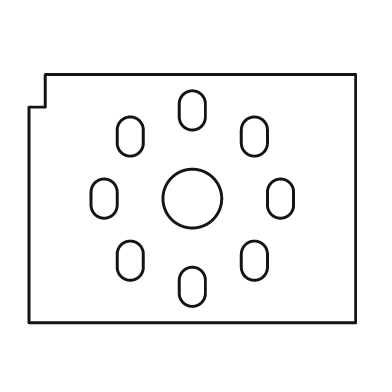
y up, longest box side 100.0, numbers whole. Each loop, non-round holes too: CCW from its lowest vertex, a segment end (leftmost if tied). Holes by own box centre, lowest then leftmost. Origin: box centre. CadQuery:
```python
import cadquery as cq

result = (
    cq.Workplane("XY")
    .moveTo(-50.0, -38.0)
    .lineTo(50.0, -38.0)
    .lineTo(50.0, 38.0)
    .lineTo(-45.0, 38.0)
    .lineTo(-45.0, 28.0)
    .lineTo(-50.0, 28.0)
    .close()
    .moveTo(-4.0, -29.0)
    .threePointArc((0.0, -33.0), (4.0, -29.0))
    .lineTo(4.0, -25.0)
    .threePointArc((0.0, -21.0), (-4.0, -25.0))
    .close()
    .moveTo(-23.0, -21.0)
    .threePointArc((-19.0, -25.0), (-15.0, -21.0))
    .lineTo(-15.0, -17.0)
    .threePointArc((-19.0, -13.0), (-23.0, -17.0))
    .close()
    .moveTo(15.0, -21.0)
    .threePointArc((19.0, -25.0), (23.0, -21.0))
    .lineTo(23.0, -17.0)
    .threePointArc((19.0, -13.0), (15.0, -17.0))
    .close()
    .moveTo(-31.0, -2.0)
    .threePointArc((-27.0, -6.0), (-23.0, -2.0))
    .lineTo(-23.0, 2.0)
    .threePointArc((-27.0, 6.0), (-31.0, 2.0))
    .close()
    .moveTo(0.0, 0.0)
    .circle(9.0)
    .moveTo(23.0, -2.0)
    .threePointArc((27.0, -6.0), (31.0, -2.0))
    .lineTo(31.0, 2.0)
    .threePointArc((27.0, 6.0), (23.0, 2.0))
    .close()
    .moveTo(-23.0, 17.0)
    .threePointArc((-19.0, 13.0), (-15.0, 17.0))
    .lineTo(-15.0, 21.0)
    .threePointArc((-19.0, 25.0), (-23.0, 21.0))
    .close()
    .moveTo(15.0, 17.0)
    .threePointArc((19.0, 13.0), (23.0, 17.0))
    .lineTo(23.0, 21.0)
    .threePointArc((19.0, 25.0), (15.0, 21.0))
    .close()
    .moveTo(-4.0, 25.0)
    .threePointArc((0.0, 21.0), (4.0, 25.0))
    .lineTo(4.0, 29.0)
    .threePointArc((0.0, 33.0), (-4.0, 29.0))
    .close()
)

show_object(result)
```